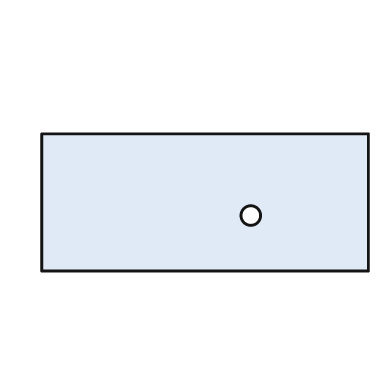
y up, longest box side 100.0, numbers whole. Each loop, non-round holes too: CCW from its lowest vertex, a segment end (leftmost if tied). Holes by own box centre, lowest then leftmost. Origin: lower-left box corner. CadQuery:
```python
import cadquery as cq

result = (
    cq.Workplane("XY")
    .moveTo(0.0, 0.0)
    .lineTo(100.0, 0.0)
    .lineTo(100.0, 42.0)
    .lineTo(0.0, 42.0)
    .close()
    .moveTo(64.0, 17.0)
    .circle(3.0)
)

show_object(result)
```